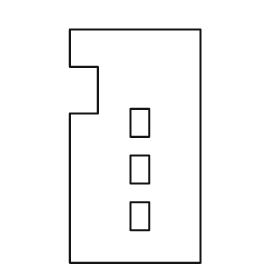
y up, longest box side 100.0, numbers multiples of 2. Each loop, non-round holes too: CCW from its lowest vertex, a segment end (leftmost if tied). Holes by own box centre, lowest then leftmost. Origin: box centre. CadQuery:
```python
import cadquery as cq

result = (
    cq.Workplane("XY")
    .moveTo(-28.0, -50.0)
    .lineTo(28.0, -50.0)
    .lineTo(28.0, 50.0)
    .lineTo(-28.0, 50.0)
    .lineTo(-28.0, 34.0)
    .lineTo(-16.0, 34.0)
    .lineTo(-16.0, 14.0)
    .lineTo(-28.0, 14.0)
    .close()
    .moveTo(-2.0, -36.0)
    .lineTo(6.0, -36.0)
    .lineTo(6.0, -24.0)
    .lineTo(-2.0, -24.0)
    .close()
    .moveTo(-2.0, -16.0)
    .lineTo(6.0, -16.0)
    .lineTo(6.0, -4.0)
    .lineTo(-2.0, -4.0)
    .close()
    .moveTo(-2.0, 4.0)
    .lineTo(6.0, 4.0)
    .lineTo(6.0, 16.0)
    .lineTo(-2.0, 16.0)
    .close()
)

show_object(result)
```